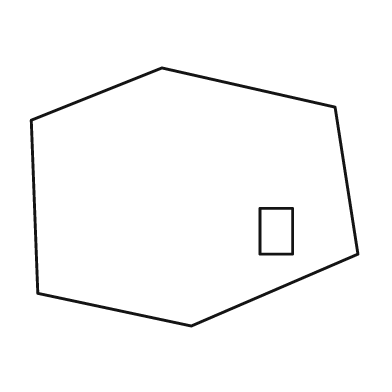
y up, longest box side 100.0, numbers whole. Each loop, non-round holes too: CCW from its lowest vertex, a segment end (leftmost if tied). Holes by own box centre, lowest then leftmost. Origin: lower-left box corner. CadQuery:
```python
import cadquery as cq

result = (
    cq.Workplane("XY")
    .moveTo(49.0, 0.0)
    .lineTo(100.0, 22.0)
    .lineTo(93.0, 67.0)
    .lineTo(40.0, 79.0)
    .lineTo(0.0, 63.0)
    .lineTo(2.0, 10.0)
    .close()
    .moveTo(70.0, 22.0)
    .lineTo(80.0, 22.0)
    .lineTo(80.0, 36.0)
    .lineTo(70.0, 36.0)
    .close()
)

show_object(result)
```